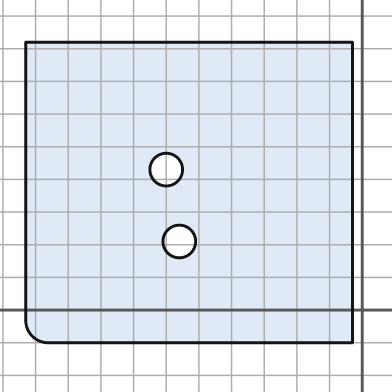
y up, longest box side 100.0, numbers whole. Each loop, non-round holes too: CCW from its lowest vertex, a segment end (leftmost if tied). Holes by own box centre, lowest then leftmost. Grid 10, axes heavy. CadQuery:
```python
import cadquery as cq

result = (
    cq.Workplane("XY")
    .moveTo(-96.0, -10.0)
    .lineTo(-3.0, -10.0)
    .lineTo(-3.0, 82.0)
    .lineTo(-103.0, 82.0)
    .lineTo(-103.0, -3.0)
    .threePointArc((-101.0, -8.0), (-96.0, -10.0))
    .close()
    .moveTo(-56.0, 21.0)
    .circle(5.0)
    .moveTo(-60.0, 43.0)
    .circle(5.0)
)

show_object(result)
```